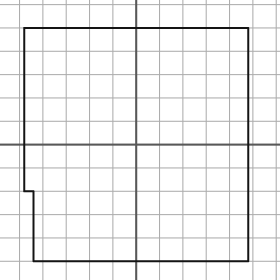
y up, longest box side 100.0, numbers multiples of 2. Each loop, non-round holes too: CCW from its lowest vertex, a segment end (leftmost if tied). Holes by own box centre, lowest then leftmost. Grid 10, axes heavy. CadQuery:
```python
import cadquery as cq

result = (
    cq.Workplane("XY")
    .moveTo(-44.0, -50.0)
    .lineTo(48.0, -50.0)
    .lineTo(48.0, 50.0)
    .lineTo(-48.0, 50.0)
    .lineTo(-48.0, -20.0)
    .lineTo(-44.0, -20.0)
    .close()
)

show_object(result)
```